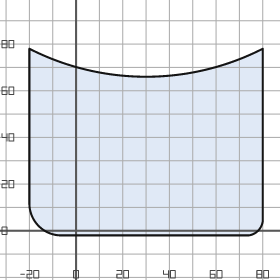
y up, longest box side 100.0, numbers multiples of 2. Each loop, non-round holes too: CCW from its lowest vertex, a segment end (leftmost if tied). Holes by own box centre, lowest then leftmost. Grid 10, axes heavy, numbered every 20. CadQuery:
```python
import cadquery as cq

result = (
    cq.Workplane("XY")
    .moveTo(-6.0, -2.0)
    .lineTo(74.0, -2.0)
    .threePointArc((78.0, 0.0), (80.0, 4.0))
    .lineTo(80.0, 78.0)
    .threePointArc((30.0, 66.0), (-20.0, 78.0))
    .lineTo(-20.0, 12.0)
    .threePointArc((-16.0, 2.0), (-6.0, -2.0))
    .close()
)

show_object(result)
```